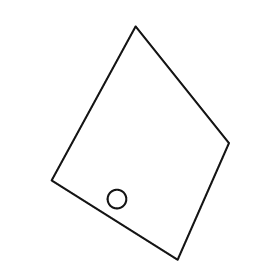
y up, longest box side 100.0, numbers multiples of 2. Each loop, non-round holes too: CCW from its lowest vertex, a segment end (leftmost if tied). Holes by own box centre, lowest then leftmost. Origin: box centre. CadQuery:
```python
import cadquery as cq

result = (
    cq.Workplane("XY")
    .moveTo(16.0, -50.0)
    .lineTo(38.0, 0.0)
    .lineTo(-2.0, 50.0)
    .lineTo(-38.0, -16.0)
    .close()
    .moveTo(-10.0, -24.0)
    .circle(4.0)
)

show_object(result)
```